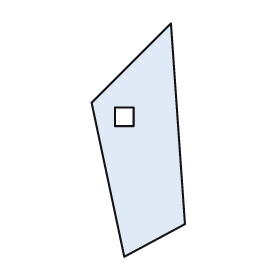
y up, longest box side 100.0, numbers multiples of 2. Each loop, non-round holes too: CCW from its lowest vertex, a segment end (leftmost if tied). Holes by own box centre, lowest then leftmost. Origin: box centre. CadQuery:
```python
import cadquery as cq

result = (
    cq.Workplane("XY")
    .moveTo(-6.0, -50.0)
    .lineTo(20.0, -36.0)
    .lineTo(14.0, 50.0)
    .lineTo(-20.0, 16.0)
    .close()
    .moveTo(-10.0, 6.0)
    .lineTo(-2.0, 6.0)
    .lineTo(-2.0, 14.0)
    .lineTo(-10.0, 14.0)
    .close()
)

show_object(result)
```